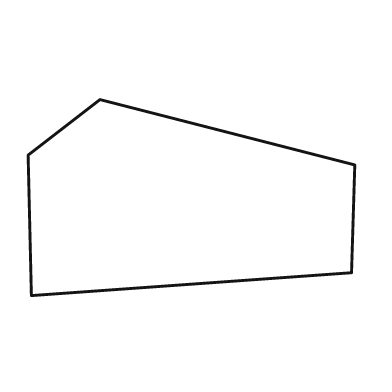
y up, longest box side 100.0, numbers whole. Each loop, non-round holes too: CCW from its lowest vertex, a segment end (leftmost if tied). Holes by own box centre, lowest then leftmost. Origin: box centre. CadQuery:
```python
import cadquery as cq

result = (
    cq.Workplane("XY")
    .moveTo(-49.0, -30.0)
    .lineTo(49.0, -23.0)
    .lineTo(50.0, 10.0)
    .lineTo(-28.0, 30.0)
    .lineTo(-50.0, 13.0)
    .close()
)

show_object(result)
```